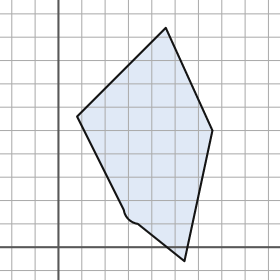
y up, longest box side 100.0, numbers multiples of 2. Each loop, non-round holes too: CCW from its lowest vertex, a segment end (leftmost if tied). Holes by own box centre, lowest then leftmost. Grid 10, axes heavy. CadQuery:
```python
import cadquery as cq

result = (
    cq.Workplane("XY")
    .moveTo(54.0, -6.0)
    .lineTo(66.0, 50.0)
    .lineTo(46.0, 94.0)
    .lineTo(8.0, 56.0)
    .lineTo(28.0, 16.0)
    .threePointArc((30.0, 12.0), (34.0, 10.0))
    .close()
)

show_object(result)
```